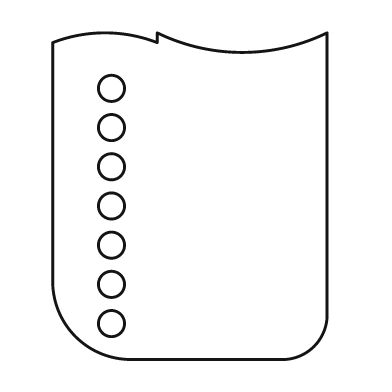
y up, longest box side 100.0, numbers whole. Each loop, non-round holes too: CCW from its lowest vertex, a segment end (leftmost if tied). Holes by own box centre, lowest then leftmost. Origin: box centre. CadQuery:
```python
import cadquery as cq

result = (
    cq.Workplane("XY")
    .moveTo(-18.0, -50.0)
    .lineTo(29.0, -50.0)
    .threePointArc((38.0, -46.0), (42.0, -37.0))
    .lineTo(42.0, 50.0)
    .threePointArc((16.0, 44.0), (-10.0, 50.0))
    .lineTo(-10.0, 47.0)
    .threePointArc((-26.0, 50.0), (-42.0, 47.0))
    .lineTo(-42.0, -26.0)
    .threePointArc((-35.0, -43.0), (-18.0, -50.0))
    .close()
    .moveTo(-24.0, -39.0)
    .circle(4.0)
    .moveTo(-24.0, -27.0)
    .circle(4.0)
    .moveTo(-24.0, -15.0)
    .circle(4.0)
    .moveTo(-24.0, -3.0)
    .circle(4.0)
    .moveTo(-24.0, 9.0)
    .circle(4.0)
    .moveTo(-24.0, 21.0)
    .circle(4.0)
    .moveTo(-24.0, 33.0)
    .circle(4.0)
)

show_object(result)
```